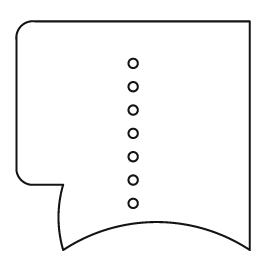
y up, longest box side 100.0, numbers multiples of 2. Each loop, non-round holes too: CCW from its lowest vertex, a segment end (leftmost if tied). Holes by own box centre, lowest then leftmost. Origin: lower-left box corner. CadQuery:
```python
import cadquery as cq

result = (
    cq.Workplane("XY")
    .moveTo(20.0, 0.0)
    .threePointArc((60.0, 12.0), (100.0, 0.0))
    .lineTo(100.0, 98.0)
    .lineTo(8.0, 98.0)
    .threePointArc((2.0, 96.0), (0.0, 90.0))
    .lineTo(0.0, 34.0)
    .threePointArc((2.0, 30.0), (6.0, 28.0))
    .lineTo(20.0, 28.0)
    .threePointArc((18.0, 14.0), (20.0, 0.0))
    .close()
    .moveTo(50.0, 20.0)
    .circle(2.0)
    .moveTo(50.0, 30.0)
    .circle(2.0)
    .moveTo(50.0, 40.0)
    .circle(2.0)
    .moveTo(50.0, 50.0)
    .circle(2.0)
    .moveTo(50.0, 60.0)
    .circle(2.0)
    .moveTo(50.0, 70.0)
    .circle(2.0)
    .moveTo(50.0, 80.0)
    .circle(2.0)
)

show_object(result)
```